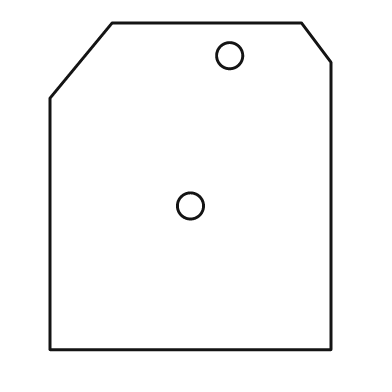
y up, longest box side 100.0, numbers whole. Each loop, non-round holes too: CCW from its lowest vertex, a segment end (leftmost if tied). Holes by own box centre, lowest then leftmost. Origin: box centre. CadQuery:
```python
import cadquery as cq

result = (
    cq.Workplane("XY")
    .moveTo(-43.0, -50.0)
    .lineTo(43.0, -50.0)
    .lineTo(43.0, 38.0)
    .lineTo(34.0, 50.0)
    .lineTo(-24.0, 50.0)
    .lineTo(-43.0, 27.0)
    .close()
    .moveTo(0.0, -6.0)
    .circle(4.0)
    .moveTo(12.0, 40.0)
    .circle(4.0)
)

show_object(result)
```